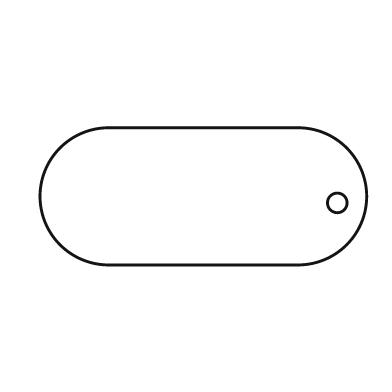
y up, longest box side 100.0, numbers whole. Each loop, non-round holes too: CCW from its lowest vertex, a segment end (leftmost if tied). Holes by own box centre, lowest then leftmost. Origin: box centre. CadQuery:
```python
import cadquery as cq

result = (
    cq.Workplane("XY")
    .moveTo(-29.0, -21.0)
    .lineTo(29.0, -21.0)
    .threePointArc((50.0, 0.0), (29.0, 21.0))
    .lineTo(-29.0, 21.0)
    .threePointArc((-50.0, 0.0), (-29.0, -21.0))
    .close()
    .moveTo(41.0, -2.0)
    .circle(3.0)
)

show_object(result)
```